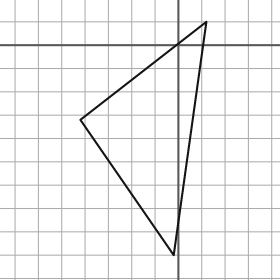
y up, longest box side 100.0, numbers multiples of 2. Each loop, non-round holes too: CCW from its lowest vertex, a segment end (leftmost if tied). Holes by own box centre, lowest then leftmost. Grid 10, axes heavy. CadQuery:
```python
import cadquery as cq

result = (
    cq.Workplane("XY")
    .moveTo(-2.0, -90.0)
    .lineTo(12.0, 10.0)
    .lineTo(-42.0, -32.0)
    .close()
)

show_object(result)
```